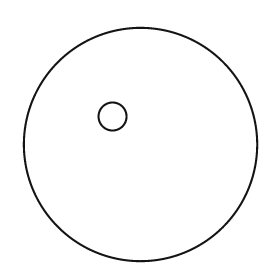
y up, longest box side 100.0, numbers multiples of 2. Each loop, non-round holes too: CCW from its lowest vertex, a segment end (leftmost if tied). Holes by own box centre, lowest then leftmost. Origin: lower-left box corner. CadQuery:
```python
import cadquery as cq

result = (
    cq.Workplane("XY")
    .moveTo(50.0, 50.0)
    .circle(50.0)
    .moveTo(38.0, 62.0)
    .circle(6.0)
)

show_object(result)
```